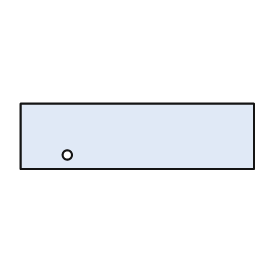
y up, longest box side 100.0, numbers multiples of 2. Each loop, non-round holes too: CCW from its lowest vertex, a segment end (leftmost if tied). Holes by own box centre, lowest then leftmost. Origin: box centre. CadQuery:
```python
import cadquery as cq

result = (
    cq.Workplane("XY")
    .moveTo(-50.0, -14.0)
    .lineTo(50.0, -14.0)
    .lineTo(50.0, 14.0)
    .lineTo(-50.0, 14.0)
    .close()
    .moveTo(-30.0, -8.0)
    .circle(2.0)
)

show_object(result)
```